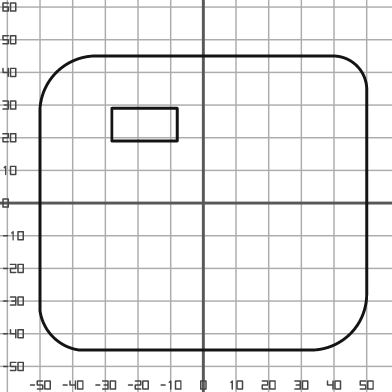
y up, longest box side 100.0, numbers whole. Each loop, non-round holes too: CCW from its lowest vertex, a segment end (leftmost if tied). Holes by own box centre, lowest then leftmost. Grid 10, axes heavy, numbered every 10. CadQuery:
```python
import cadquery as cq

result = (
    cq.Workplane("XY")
    .moveTo(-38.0, -45.0)
    .lineTo(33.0, -45.0)
    .threePointArc((45.0, -40.0), (50.0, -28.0))
    .lineTo(50.0, 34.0)
    .threePointArc((47.0, 42.0), (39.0, 45.0))
    .lineTo(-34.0, 45.0)
    .threePointArc((-45.0, 40.0), (-50.0, 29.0))
    .lineTo(-50.0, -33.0)
    .threePointArc((-46.0, -41.0), (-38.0, -45.0))
    .close()
    .moveTo(-28.0, 19.0)
    .lineTo(-8.0, 19.0)
    .lineTo(-8.0, 29.0)
    .lineTo(-28.0, 29.0)
    .close()
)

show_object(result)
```